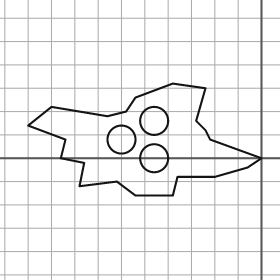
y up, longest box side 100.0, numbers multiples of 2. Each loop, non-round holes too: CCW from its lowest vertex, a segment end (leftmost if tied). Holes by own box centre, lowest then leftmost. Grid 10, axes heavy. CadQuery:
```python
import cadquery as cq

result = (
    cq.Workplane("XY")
    .moveTo(-54.0, -16.0)
    .lineTo(-38.0, -16.0)
    .lineTo(-36.0, -8.0)
    .lineTo(-20.0, -8.0)
    .lineTo(-6.0, -4.0)
    .lineTo(0.0, 0.0)
    .lineTo(-22.0, 8.0)
    .lineTo(-24.0, 12.0)
    .lineTo(-28.0, 16.0)
    .lineTo(-24.0, 30.0)
    .lineTo(-38.0, 32.0)
    .lineTo(-54.0, 26.0)
    .lineTo(-58.0, 20.0)
    .lineTo(-66.0, 18.0)
    .lineTo(-90.0, 22.0)
    .lineTo(-100.0, 14.0)
    .lineTo(-84.0, 8.0)
    .lineTo(-86.0, 0.0)
    .lineTo(-76.0, -2.0)
    .lineTo(-78.0, -12.0)
    .lineTo(-62.0, -10.0)
    .close()
    .moveTo(-46.0, 0.0)
    .circle(6.0)
    .moveTo(-60.0, 8.0)
    .circle(6.0)
    .moveTo(-46.0, 16.0)
    .circle(6.0)
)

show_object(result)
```